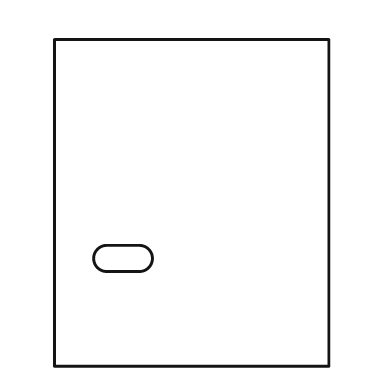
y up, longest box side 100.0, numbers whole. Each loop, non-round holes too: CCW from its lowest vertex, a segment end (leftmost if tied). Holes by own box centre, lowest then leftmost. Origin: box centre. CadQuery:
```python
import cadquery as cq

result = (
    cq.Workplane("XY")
    .moveTo(-42.0, -50.0)
    .lineTo(42.0, -50.0)
    .lineTo(42.0, 50.0)
    .lineTo(-42.0, 50.0)
    .close()
    .moveTo(-26.0, -21.0)
    .lineTo(-16.0, -21.0)
    .threePointArc((-12.0, -17.0), (-16.0, -13.0))
    .lineTo(-26.0, -13.0)
    .threePointArc((-30.0, -17.0), (-26.0, -21.0))
    .close()
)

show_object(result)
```